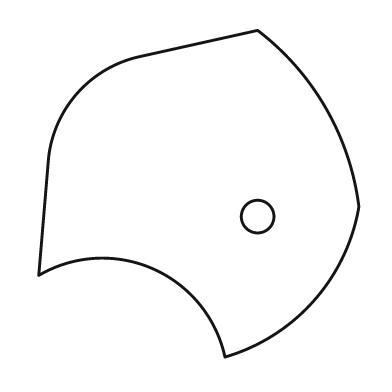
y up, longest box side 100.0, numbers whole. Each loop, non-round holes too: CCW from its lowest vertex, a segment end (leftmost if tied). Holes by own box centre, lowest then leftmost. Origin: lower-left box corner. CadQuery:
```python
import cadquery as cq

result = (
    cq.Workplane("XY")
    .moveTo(57.0, 0.0)
    .threePointArc((84.0, 17.0), (98.0, 46.0))
    .threePointArc((88.0, 76.0), (67.0, 100.0))
    .lineTo(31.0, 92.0)
    .threePointArc((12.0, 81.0), (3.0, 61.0))
    .lineTo(0.0, 25.0)
    .threePointArc((35.0, 27.0), (57.0, 0.0))
    .close()
    .moveTo(67.0, 43.0)
    .circle(5.0)
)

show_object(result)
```